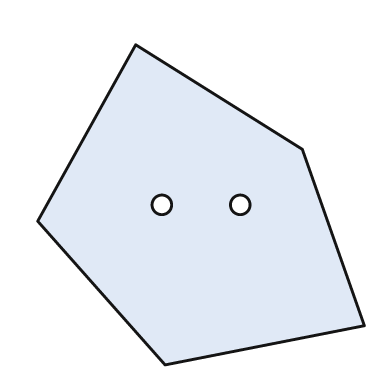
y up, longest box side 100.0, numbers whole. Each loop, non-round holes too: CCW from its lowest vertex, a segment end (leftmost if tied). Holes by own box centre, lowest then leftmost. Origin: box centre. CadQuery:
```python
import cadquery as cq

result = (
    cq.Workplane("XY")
    .moveTo(-11.0, -49.0)
    .lineTo(50.0, -37.0)
    .lineTo(31.0, 17.0)
    .lineTo(-20.0, 49.0)
    .lineTo(-50.0, -5.0)
    .close()
    .moveTo(-12.0, 0.0)
    .circle(3.0)
    .moveTo(12.0, 0.0)
    .circle(3.0)
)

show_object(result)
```